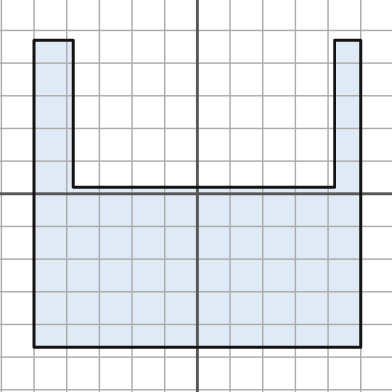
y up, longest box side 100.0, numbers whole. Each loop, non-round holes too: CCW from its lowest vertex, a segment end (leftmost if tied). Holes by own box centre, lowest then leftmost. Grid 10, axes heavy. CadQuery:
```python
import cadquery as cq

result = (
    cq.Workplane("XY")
    .moveTo(-50.0, -47.0)
    .lineTo(50.0, -47.0)
    .lineTo(50.0, 47.0)
    .lineTo(42.0, 47.0)
    .lineTo(42.0, 2.0)
    .lineTo(-38.0, 2.0)
    .lineTo(-38.0, 47.0)
    .lineTo(-50.0, 47.0)
    .close()
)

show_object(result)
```